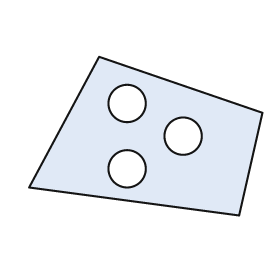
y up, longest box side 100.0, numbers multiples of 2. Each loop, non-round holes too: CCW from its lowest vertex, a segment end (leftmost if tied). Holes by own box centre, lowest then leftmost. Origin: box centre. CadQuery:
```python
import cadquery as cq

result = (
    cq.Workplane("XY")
    .moveTo(40.0, -34.0)
    .lineTo(50.0, 10.0)
    .lineTo(-20.0, 34.0)
    .lineTo(-50.0, -22.0)
    .close()
    .moveTo(-8.0, -14.0)
    .circle(8.0)
    .moveTo(16.0, 0.0)
    .circle(8.0)
    .moveTo(-8.0, 14.0)
    .circle(8.0)
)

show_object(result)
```